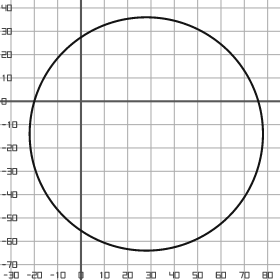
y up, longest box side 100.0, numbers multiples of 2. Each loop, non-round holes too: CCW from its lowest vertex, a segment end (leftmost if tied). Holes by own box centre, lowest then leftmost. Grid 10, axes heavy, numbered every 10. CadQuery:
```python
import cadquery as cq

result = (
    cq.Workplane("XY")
    .moveTo(28.0, -14.0)
    .circle(50.0)
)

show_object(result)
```